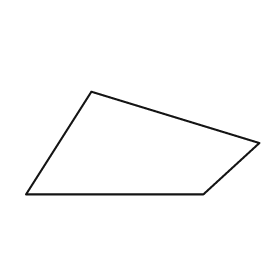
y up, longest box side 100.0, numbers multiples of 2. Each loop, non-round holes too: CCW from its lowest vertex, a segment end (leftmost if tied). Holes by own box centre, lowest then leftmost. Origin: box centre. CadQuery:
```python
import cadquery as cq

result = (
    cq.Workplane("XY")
    .moveTo(-50.0, -22.0)
    .lineTo(26.0, -22.0)
    .lineTo(50.0, 0.0)
    .lineTo(-22.0, 22.0)
    .close()
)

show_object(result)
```